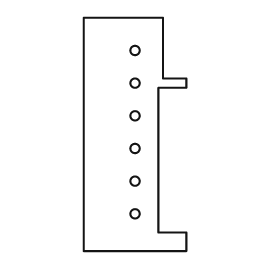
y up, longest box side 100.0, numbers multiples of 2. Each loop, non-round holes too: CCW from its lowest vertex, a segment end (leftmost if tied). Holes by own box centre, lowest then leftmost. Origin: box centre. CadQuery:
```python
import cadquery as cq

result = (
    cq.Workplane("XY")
    .moveTo(-22.0, -50.0)
    .lineTo(22.0, -50.0)
    .lineTo(22.0, -42.0)
    .lineTo(10.0, -42.0)
    .lineTo(10.0, 20.0)
    .lineTo(22.0, 20.0)
    .lineTo(22.0, 24.0)
    .lineTo(12.0, 24.0)
    .lineTo(12.0, 50.0)
    .lineTo(-22.0, 50.0)
    .close()
    .moveTo(0.0, -34.0)
    .circle(2.0)
    .moveTo(0.0, -20.0)
    .circle(2.0)
    .moveTo(0.0, -6.0)
    .circle(2.0)
    .moveTo(0.0, 8.0)
    .circle(2.0)
    .moveTo(0.0, 22.0)
    .circle(2.0)
    .moveTo(0.0, 36.0)
    .circle(2.0)
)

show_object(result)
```